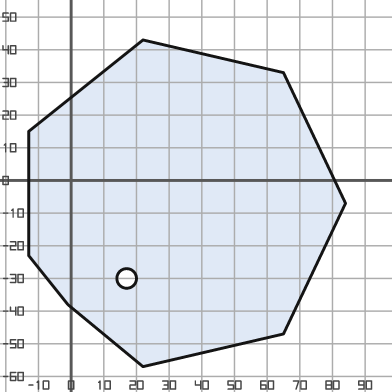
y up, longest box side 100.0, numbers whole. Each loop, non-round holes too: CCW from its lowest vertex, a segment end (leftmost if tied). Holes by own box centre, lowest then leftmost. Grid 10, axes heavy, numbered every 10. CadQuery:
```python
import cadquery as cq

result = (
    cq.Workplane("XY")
    .moveTo(22.0, -57.0)
    .lineTo(65.0, -47.0)
    .lineTo(84.0, -7.0)
    .lineTo(65.0, 33.0)
    .lineTo(22.0, 43.0)
    .lineTo(-13.0, 15.0)
    .lineTo(-13.0, -23.0)
    .lineTo(-1.0, -38.0)
    .close()
    .moveTo(17.0, -30.0)
    .circle(3.0)
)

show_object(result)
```